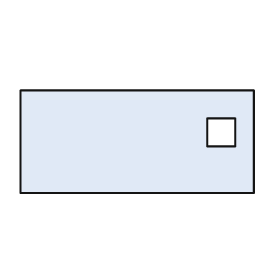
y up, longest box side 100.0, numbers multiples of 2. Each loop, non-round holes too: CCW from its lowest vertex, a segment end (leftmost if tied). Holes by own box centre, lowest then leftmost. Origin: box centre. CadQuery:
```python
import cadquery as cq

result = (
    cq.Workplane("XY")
    .moveTo(-50.0, -22.0)
    .lineTo(50.0, -22.0)
    .lineTo(50.0, 22.0)
    .lineTo(-50.0, 22.0)
    .close()
    .moveTo(30.0, -2.0)
    .lineTo(42.0, -2.0)
    .lineTo(42.0, 10.0)
    .lineTo(30.0, 10.0)
    .close()
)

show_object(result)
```